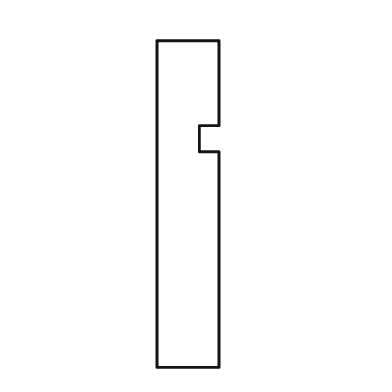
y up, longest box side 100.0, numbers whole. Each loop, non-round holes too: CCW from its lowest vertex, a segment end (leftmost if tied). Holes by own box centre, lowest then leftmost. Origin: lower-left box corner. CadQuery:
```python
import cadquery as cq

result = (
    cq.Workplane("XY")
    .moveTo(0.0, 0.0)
    .lineTo(19.0, 0.0)
    .lineTo(19.0, 66.0)
    .lineTo(13.0, 66.0)
    .lineTo(13.0, 74.0)
    .lineTo(19.0, 74.0)
    .lineTo(19.0, 100.0)
    .lineTo(0.0, 100.0)
    .close()
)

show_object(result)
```